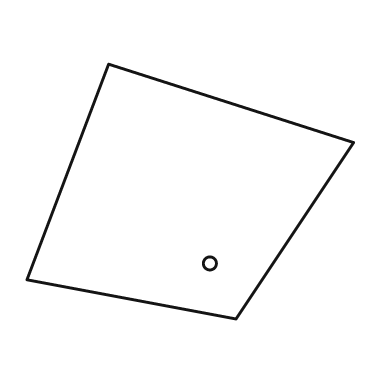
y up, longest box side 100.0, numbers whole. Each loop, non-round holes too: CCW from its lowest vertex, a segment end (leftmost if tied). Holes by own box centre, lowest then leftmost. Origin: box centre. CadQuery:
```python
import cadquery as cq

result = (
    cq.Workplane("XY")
    .moveTo(14.0, -39.0)
    .lineTo(50.0, 15.0)
    .lineTo(-25.0, 39.0)
    .lineTo(-50.0, -27.0)
    .close()
    .moveTo(6.0, -22.0)
    .circle(2.0)
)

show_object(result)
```